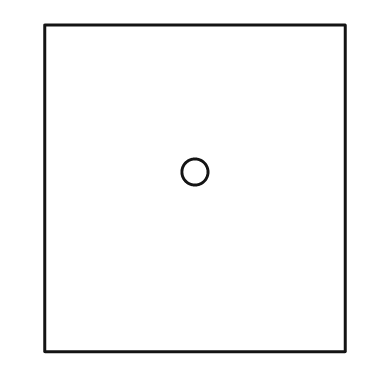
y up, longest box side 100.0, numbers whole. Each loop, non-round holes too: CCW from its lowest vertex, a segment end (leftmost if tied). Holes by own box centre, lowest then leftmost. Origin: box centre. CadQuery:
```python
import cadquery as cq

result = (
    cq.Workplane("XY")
    .moveTo(-46.0, -50.0)
    .lineTo(46.0, -50.0)
    .lineTo(46.0, 50.0)
    .lineTo(-46.0, 50.0)
    .close()
    .moveTo(0.0, 5.0)
    .circle(4.0)
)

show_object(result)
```